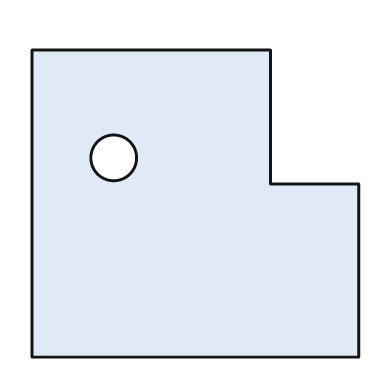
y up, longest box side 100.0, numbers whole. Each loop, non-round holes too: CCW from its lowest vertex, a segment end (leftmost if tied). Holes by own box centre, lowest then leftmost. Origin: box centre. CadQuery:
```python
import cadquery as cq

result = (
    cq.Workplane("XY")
    .moveTo(-50.0, -47.0)
    .lineTo(50.0, -47.0)
    .lineTo(50.0, 6.0)
    .lineTo(23.0, 6.0)
    .lineTo(23.0, 47.0)
    .lineTo(-50.0, 47.0)
    .close()
    .moveTo(-25.0, 14.0)
    .circle(7.0)
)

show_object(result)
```